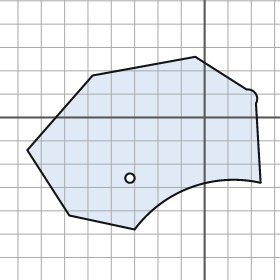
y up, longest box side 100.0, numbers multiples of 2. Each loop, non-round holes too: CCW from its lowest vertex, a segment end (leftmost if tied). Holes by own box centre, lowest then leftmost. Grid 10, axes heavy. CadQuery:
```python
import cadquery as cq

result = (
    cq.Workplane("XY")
    .moveTo(-30.0, -48.0)
    .threePointArc((-6.0, -30.0), (24.0, -28.0))
    .lineTo(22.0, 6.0)
    .threePointArc((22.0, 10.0), (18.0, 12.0))
    .lineTo(-4.0, 26.0)
    .lineTo(-48.0, 18.0)
    .lineTo(-76.0, -14.0)
    .lineTo(-58.0, -42.0)
    .close()
    .moveTo(-32.0, -26.0)
    .circle(2.0)
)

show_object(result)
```